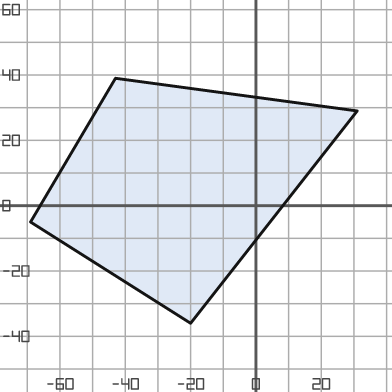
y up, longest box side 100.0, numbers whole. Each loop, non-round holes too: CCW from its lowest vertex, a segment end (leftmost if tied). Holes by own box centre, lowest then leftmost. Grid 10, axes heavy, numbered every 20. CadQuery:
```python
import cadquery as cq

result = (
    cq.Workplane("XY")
    .moveTo(-20.0, -36.0)
    .lineTo(31.0, 29.0)
    .lineTo(-43.0, 39.0)
    .lineTo(-69.0, -5.0)
    .close()
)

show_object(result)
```